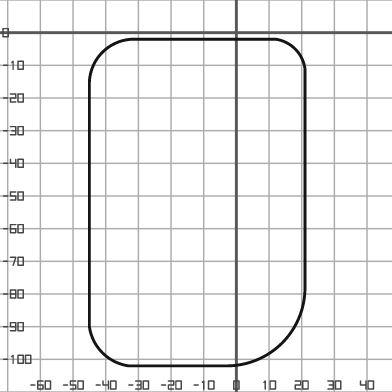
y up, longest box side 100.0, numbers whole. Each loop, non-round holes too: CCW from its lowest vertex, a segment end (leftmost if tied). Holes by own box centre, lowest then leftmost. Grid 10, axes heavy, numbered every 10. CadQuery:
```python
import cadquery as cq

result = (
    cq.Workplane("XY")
    .moveTo(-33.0, -102.0)
    .lineTo(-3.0, -102.0)
    .threePointArc((14.0, -95.0), (21.0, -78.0))
    .lineTo(21.0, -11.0)
    .threePointArc((18.0, -5.0), (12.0, -2.0))
    .lineTo(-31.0, -2.0)
    .threePointArc((-41.0, -6.0), (-45.0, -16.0))
    .lineTo(-45.0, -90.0)
    .threePointArc((-41.0, -98.0), (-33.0, -102.0))
    .close()
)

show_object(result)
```